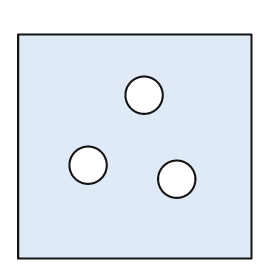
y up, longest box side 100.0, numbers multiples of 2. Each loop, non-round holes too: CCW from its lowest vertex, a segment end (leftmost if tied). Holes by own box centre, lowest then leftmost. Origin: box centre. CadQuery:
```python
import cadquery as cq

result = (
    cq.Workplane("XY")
    .moveTo(-50.0, -48.0)
    .lineTo(50.0, -48.0)
    .lineTo(50.0, 48.0)
    .lineTo(-50.0, 48.0)
    .close()
    .moveTo(18.0, -14.0)
    .circle(8.0)
    .moveTo(-20.0, -8.0)
    .circle(8.0)
    .moveTo(4.0, 22.0)
    .circle(8.0)
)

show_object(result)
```